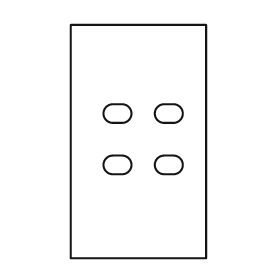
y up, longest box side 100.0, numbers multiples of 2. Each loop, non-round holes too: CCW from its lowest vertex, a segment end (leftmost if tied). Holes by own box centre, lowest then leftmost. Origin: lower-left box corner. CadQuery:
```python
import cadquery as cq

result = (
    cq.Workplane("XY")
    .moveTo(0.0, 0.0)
    .lineTo(58.0, 0.0)
    .lineTo(58.0, 100.0)
    .lineTo(0.0, 100.0)
    .close()
    .moveTo(18.0, 36.0)
    .lineTo(22.0, 36.0)
    .threePointArc((26.0, 40.0), (22.0, 44.0))
    .lineTo(18.0, 44.0)
    .threePointArc((14.0, 40.0), (18.0, 36.0))
    .close()
    .moveTo(40.0, 36.0)
    .lineTo(44.0, 36.0)
    .threePointArc((48.0, 40.0), (44.0, 44.0))
    .lineTo(40.0, 44.0)
    .threePointArc((36.0, 40.0), (40.0, 36.0))
    .close()
    .moveTo(18.0, 58.0)
    .lineTo(22.0, 58.0)
    .threePointArc((26.0, 62.0), (22.0, 66.0))
    .lineTo(18.0, 66.0)
    .threePointArc((14.0, 62.0), (18.0, 58.0))
    .close()
    .moveTo(40.0, 58.0)
    .lineTo(44.0, 58.0)
    .threePointArc((48.0, 62.0), (44.0, 66.0))
    .lineTo(40.0, 66.0)
    .threePointArc((36.0, 62.0), (40.0, 58.0))
    .close()
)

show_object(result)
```